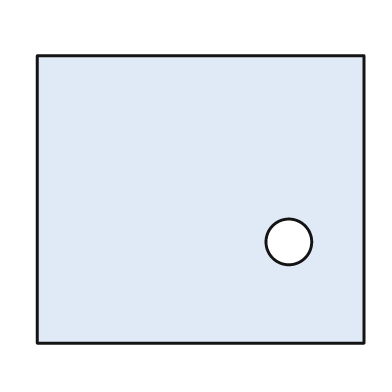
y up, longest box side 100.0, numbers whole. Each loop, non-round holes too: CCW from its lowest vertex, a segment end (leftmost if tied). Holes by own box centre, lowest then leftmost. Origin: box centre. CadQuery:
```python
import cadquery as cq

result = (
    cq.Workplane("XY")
    .moveTo(-50.0, -44.0)
    .lineTo(50.0, -44.0)
    .lineTo(50.0, 44.0)
    .lineTo(-50.0, 44.0)
    .close()
    .moveTo(27.0, -13.0)
    .circle(7.0)
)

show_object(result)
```